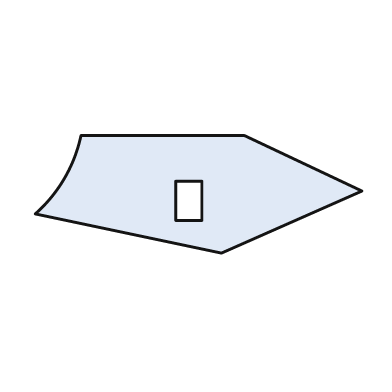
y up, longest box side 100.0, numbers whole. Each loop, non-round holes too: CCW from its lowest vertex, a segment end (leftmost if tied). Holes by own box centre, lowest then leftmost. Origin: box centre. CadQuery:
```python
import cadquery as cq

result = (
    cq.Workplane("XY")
    .moveTo(7.0, -18.0)
    .lineTo(50.0, 1.0)
    .lineTo(14.0, 18.0)
    .lineTo(-36.0, 18.0)
    .threePointArc((-41.0, 5.0), (-50.0, -6.0))
    .close()
    .moveTo(-7.0, -8.0)
    .lineTo(1.0, -8.0)
    .lineTo(1.0, 4.0)
    .lineTo(-7.0, 4.0)
    .close()
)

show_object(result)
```